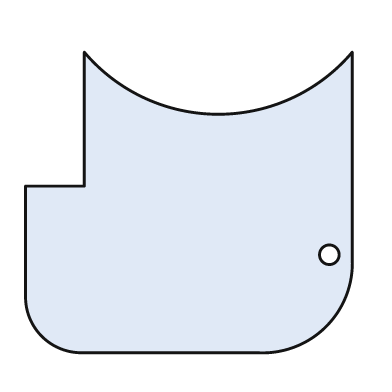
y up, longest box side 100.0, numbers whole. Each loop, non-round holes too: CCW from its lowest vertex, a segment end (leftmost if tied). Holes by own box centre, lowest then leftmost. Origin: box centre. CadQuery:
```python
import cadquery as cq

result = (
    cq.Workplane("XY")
    .moveTo(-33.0, -46.0)
    .lineTo(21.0, -46.0)
    .threePointArc((42.0, -38.0), (50.0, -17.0))
    .lineTo(50.0, 46.0)
    .threePointArc((9.0, 27.0), (-32.0, 46.0))
    .lineTo(-32.0, 5.0)
    .lineTo(-50.0, 5.0)
    .lineTo(-50.0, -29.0)
    .threePointArc((-45.0, -41.0), (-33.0, -46.0))
    .close()
    .moveTo(43.0, -16.0)
    .circle(3.0)
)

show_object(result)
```